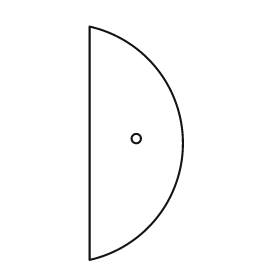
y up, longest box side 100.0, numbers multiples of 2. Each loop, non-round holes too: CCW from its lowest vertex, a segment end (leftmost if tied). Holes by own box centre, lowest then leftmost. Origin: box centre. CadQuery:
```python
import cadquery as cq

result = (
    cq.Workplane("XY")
    .moveTo(-20.0, -50.0)
    .threePointArc((20.0, 0.0), (-20.0, 50.0))
    .close()
    .moveTo(0.0, 2.0)
    .circle(2.0)
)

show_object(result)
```